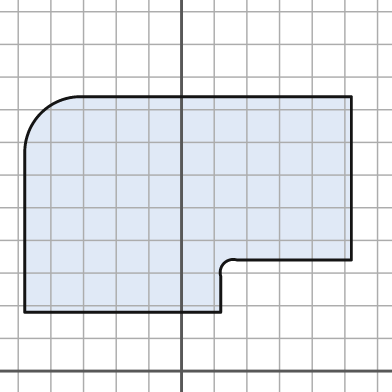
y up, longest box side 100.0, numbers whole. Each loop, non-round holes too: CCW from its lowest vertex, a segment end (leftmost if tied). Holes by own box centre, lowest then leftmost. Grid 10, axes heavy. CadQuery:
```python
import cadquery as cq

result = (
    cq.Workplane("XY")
    .moveTo(-48.0, 18.0)
    .lineTo(12.0, 18.0)
    .lineTo(12.0, 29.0)
    .threePointArc((13.0, 33.0), (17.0, 34.0))
    .lineTo(52.0, 34.0)
    .lineTo(52.0, 84.0)
    .lineTo(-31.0, 84.0)
    .threePointArc((-43.0, 79.0), (-48.0, 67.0))
    .close()
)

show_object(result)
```